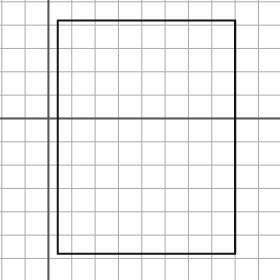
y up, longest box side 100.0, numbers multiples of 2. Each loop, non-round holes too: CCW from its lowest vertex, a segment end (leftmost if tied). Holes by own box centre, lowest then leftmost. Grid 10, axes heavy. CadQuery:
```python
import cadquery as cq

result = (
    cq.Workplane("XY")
    .moveTo(4.0, -58.0)
    .lineTo(80.0, -58.0)
    .lineTo(80.0, 42.0)
    .lineTo(4.0, 42.0)
    .close()
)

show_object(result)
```